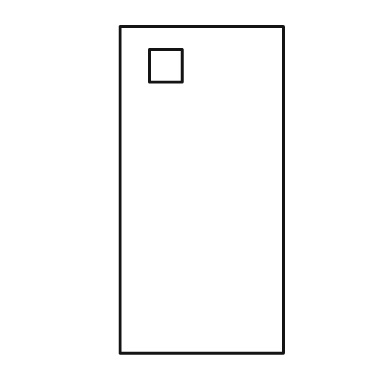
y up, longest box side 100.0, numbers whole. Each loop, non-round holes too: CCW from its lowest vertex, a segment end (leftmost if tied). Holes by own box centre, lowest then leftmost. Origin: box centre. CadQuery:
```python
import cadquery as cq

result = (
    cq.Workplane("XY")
    .moveTo(-25.0, -50.0)
    .lineTo(25.0, -50.0)
    .lineTo(25.0, 50.0)
    .lineTo(-25.0, 50.0)
    .close()
    .moveTo(-16.0, 33.0)
    .lineTo(-6.0, 33.0)
    .lineTo(-6.0, 43.0)
    .lineTo(-16.0, 43.0)
    .close()
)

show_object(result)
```